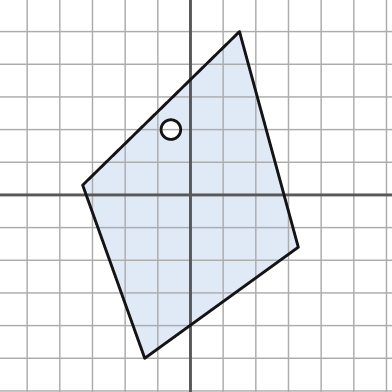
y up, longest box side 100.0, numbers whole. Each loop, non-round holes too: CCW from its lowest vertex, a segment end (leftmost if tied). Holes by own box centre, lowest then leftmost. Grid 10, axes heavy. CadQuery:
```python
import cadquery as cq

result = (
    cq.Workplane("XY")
    .moveTo(-14.0, -50.0)
    .lineTo(33.0, -16.0)
    .lineTo(15.0, 50.0)
    .lineTo(-33.0, 3.0)
    .close()
    .moveTo(-6.0, 20.0)
    .circle(3.0)
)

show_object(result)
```